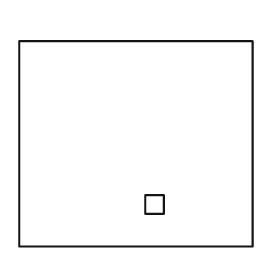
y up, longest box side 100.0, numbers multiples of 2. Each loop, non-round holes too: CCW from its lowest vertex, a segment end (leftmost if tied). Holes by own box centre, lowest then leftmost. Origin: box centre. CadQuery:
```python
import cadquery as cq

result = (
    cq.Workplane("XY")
    .moveTo(-50.0, -44.0)
    .lineTo(50.0, -44.0)
    .lineTo(50.0, 44.0)
    .lineTo(-50.0, 44.0)
    .close()
    .moveTo(4.0, -30.0)
    .lineTo(12.0, -30.0)
    .lineTo(12.0, -22.0)
    .lineTo(4.0, -22.0)
    .close()
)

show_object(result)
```